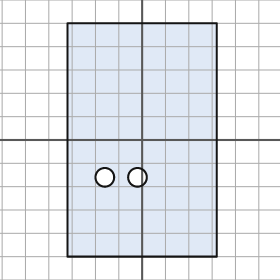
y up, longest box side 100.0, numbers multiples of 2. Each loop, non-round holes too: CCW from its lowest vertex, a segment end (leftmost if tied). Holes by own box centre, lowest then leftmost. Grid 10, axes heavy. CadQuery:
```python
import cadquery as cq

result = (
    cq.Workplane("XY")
    .moveTo(-32.0, -50.0)
    .lineTo(32.0, -50.0)
    .lineTo(32.0, 50.0)
    .lineTo(-32.0, 50.0)
    .close()
    .moveTo(-16.0, -16.0)
    .circle(4.0)
    .moveTo(-2.0, -16.0)
    .circle(4.0)
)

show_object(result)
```